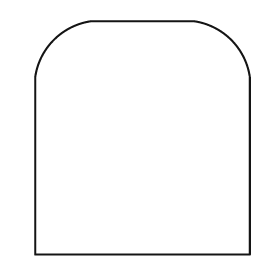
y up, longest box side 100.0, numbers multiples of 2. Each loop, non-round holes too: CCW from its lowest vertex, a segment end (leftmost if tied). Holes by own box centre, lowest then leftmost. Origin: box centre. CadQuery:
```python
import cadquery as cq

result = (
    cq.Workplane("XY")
    .moveTo(-46.0, -50.0)
    .lineTo(46.0, -50.0)
    .lineTo(46.0, 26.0)
    .threePointArc((38.0, 42.0), (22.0, 50.0))
    .lineTo(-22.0, 50.0)
    .threePointArc((-38.0, 42.0), (-46.0, 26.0))
    .close()
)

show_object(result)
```